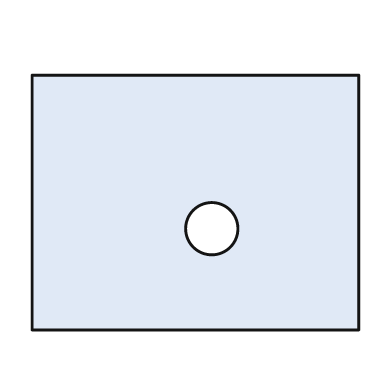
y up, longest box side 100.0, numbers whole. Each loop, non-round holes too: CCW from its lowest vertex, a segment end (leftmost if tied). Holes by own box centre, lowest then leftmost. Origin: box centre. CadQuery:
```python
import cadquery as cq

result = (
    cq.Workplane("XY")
    .moveTo(-50.0, -39.0)
    .lineTo(50.0, -39.0)
    .lineTo(50.0, 39.0)
    .lineTo(-50.0, 39.0)
    .close()
    .moveTo(5.0, -8.0)
    .circle(8.0)
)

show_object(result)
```